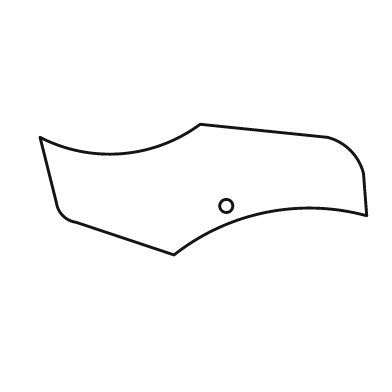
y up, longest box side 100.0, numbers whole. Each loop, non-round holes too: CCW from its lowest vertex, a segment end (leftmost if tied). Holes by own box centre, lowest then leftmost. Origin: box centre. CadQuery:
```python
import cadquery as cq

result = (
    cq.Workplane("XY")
    .moveTo(-9.0, -20.0)
    .threePointArc((19.0, -7.0), (50.0, -8.0))
    .lineTo(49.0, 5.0)
    .threePointArc((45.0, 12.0), (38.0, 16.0))
    .lineTo(-1.0, 20.0)
    .threePointArc((-25.0, 11.0), (-50.0, 16.0))
    .lineTo(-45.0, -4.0)
    .threePointArc((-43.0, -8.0), (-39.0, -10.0))
    .close()
    .moveTo(7.0, -5.0)
    .circle(2.0)
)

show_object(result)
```